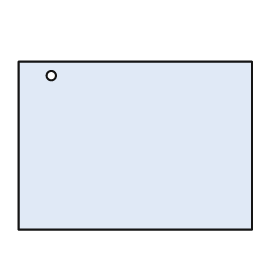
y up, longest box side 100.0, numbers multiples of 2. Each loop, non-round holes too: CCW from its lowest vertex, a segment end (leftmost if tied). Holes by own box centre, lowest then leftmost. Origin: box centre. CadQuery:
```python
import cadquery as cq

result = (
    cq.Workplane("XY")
    .moveTo(-50.0, -36.0)
    .lineTo(50.0, -36.0)
    .lineTo(50.0, 36.0)
    .lineTo(-50.0, 36.0)
    .close()
    .moveTo(-36.0, 30.0)
    .circle(2.0)
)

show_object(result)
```